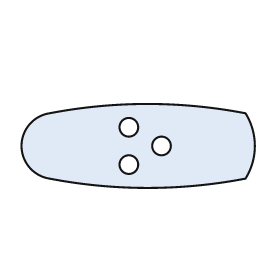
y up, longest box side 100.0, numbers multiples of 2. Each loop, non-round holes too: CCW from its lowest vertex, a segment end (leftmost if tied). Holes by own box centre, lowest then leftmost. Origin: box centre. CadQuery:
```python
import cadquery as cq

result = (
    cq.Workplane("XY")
    .moveTo(-38.0, -14.0)
    .threePointArc((4.0, -18.0), (46.0, -14.0))
    .threePointArc((50.0, 0.0), (46.0, 14.0))
    .threePointArc((4.0, 18.0), (-38.0, 14.0))
    .threePointArc((-50.0, 0.0), (-38.0, -14.0))
    .close()
    .moveTo(-4.0, -8.0)
    .circle(4.0)
    .moveTo(10.0, 0.0)
    .circle(4.0)
    .moveTo(-4.0, 8.0)
    .circle(4.0)
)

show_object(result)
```